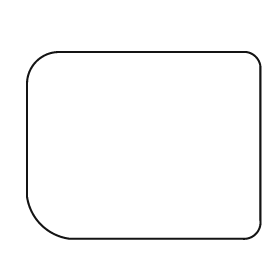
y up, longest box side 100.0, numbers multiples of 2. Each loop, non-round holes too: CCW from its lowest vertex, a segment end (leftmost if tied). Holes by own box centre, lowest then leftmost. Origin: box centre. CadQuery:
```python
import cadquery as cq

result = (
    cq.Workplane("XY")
    .moveTo(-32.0, -40.0)
    .lineTo(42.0, -40.0)
    .threePointArc((48.0, -38.0), (50.0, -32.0))
    .lineTo(50.0, 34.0)
    .threePointArc((48.0, 38.0), (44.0, 40.0))
    .lineTo(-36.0, 40.0)
    .threePointArc((-46.0, 36.0), (-50.0, 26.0))
    .lineTo(-50.0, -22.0)
    .threePointArc((-44.0, -34.0), (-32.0, -40.0))
    .close()
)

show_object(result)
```